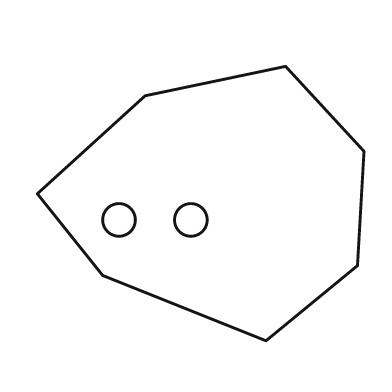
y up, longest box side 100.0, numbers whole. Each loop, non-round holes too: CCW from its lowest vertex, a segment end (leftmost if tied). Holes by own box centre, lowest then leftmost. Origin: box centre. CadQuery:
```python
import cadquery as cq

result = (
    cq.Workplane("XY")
    .moveTo(20.0, -42.0)
    .lineTo(48.0, -19.0)
    .lineTo(50.0, 16.0)
    .lineTo(26.0, 42.0)
    .lineTo(-17.0, 33.0)
    .lineTo(-50.0, 3.0)
    .lineTo(-30.0, -22.0)
    .close()
    .moveTo(-25.0, -5.0)
    .circle(5.0)
    .moveTo(-3.0, -5.0)
    .circle(5.0)
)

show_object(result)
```